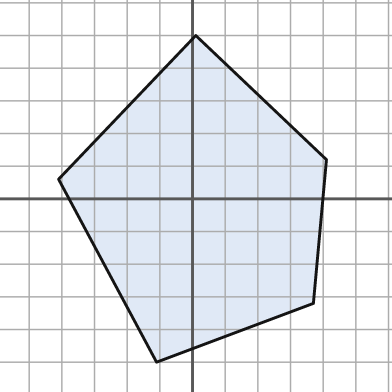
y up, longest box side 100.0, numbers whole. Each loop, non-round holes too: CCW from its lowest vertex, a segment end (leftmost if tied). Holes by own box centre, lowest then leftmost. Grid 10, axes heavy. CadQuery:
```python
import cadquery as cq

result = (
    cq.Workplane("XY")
    .moveTo(-11.0, -50.0)
    .lineTo(37.0, -32.0)
    .lineTo(41.0, 12.0)
    .lineTo(1.0, 50.0)
    .lineTo(-41.0, 6.0)
    .close()
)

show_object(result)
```